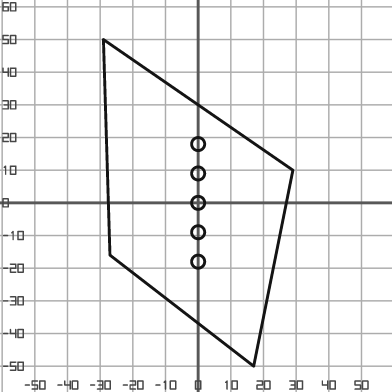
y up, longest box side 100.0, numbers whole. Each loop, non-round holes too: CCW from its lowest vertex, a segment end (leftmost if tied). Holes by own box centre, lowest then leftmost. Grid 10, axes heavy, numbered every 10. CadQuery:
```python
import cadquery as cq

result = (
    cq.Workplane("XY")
    .moveTo(17.0, -50.0)
    .lineTo(29.0, 10.0)
    .lineTo(-29.0, 50.0)
    .lineTo(-27.0, -16.0)
    .close()
    .moveTo(0.0, -18.0)
    .circle(2.0)
    .moveTo(0.0, -9.0)
    .circle(2.0)
    .moveTo(0.0, 0.0)
    .circle(2.0)
    .moveTo(0.0, 9.0)
    .circle(2.0)
    .moveTo(0.0, 18.0)
    .circle(2.0)
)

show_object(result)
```